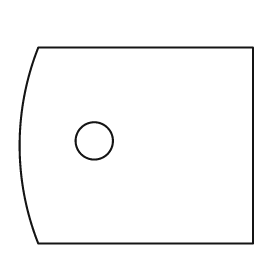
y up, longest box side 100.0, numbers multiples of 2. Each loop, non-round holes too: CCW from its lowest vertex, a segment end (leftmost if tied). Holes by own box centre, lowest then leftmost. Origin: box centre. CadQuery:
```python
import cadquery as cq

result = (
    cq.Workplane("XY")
    .moveTo(-42.0, -42.0)
    .lineTo(50.0, -42.0)
    .lineTo(50.0, 42.0)
    .lineTo(-42.0, 42.0)
    .threePointArc((-50.0, 0.0), (-42.0, -42.0))
    .close()
    .moveTo(-18.0, 2.0)
    .circle(8.0)
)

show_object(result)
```